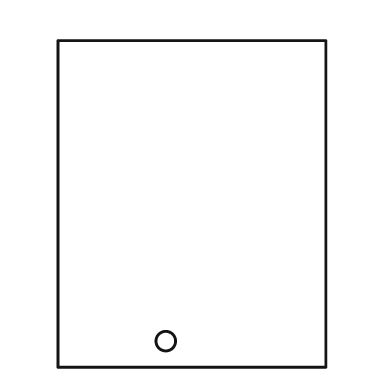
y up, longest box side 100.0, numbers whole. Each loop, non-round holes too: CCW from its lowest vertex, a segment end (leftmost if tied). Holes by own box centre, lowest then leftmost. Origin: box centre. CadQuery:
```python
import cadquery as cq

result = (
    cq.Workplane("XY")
    .moveTo(-41.0, -50.0)
    .lineTo(41.0, -50.0)
    .lineTo(41.0, 50.0)
    .lineTo(-41.0, 50.0)
    .close()
    .moveTo(-8.0, -42.0)
    .circle(3.0)
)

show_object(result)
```